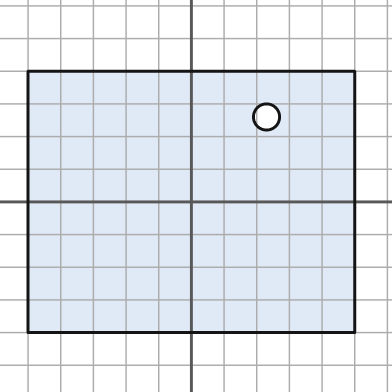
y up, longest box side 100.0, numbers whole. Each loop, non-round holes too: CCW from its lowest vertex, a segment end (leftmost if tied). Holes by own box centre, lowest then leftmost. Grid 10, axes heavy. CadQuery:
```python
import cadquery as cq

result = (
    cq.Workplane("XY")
    .moveTo(-50.0, -40.0)
    .lineTo(50.0, -40.0)
    .lineTo(50.0, 40.0)
    .lineTo(-50.0, 40.0)
    .close()
    .moveTo(23.0, 26.0)
    .circle(4.0)
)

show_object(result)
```